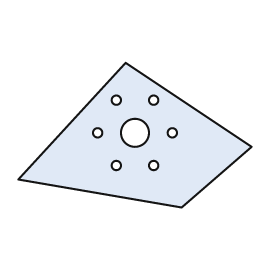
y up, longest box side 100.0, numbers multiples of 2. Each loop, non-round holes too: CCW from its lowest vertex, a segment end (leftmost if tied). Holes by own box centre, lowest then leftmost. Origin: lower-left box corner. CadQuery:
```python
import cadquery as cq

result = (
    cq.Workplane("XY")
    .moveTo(70.0, 0.0)
    .lineTo(100.0, 26.0)
    .lineTo(46.0, 62.0)
    .lineTo(0.0, 12.0)
    .close()
    .moveTo(42.0, 18.0)
    .circle(2.0)
    .moveTo(58.0, 18.0)
    .circle(2.0)
    .moveTo(34.0, 32.0)
    .circle(2.0)
    .moveTo(50.0, 32.0)
    .circle(6.0)
    .moveTo(66.0, 32.0)
    .circle(2.0)
    .moveTo(42.0, 46.0)
    .circle(2.0)
    .moveTo(58.0, 46.0)
    .circle(2.0)
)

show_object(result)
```